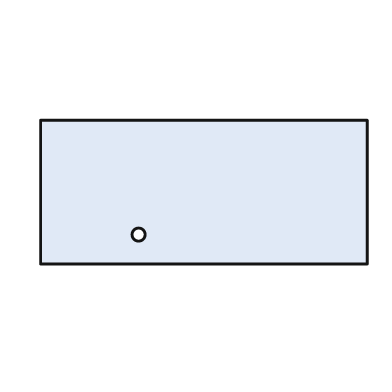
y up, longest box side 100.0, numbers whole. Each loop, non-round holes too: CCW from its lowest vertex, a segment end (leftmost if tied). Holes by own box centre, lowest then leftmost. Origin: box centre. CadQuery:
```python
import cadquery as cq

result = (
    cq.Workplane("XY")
    .moveTo(-50.0, -22.0)
    .lineTo(50.0, -22.0)
    .lineTo(50.0, 22.0)
    .lineTo(-50.0, 22.0)
    .close()
    .moveTo(-20.0, -13.0)
    .circle(2.0)
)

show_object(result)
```